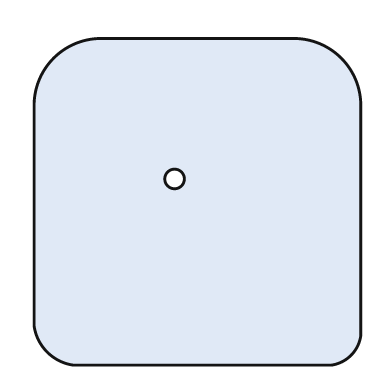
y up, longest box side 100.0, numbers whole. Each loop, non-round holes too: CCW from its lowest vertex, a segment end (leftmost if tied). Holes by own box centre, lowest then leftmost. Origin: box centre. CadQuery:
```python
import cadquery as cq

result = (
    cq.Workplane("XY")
    .moveTo(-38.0, -50.0)
    .lineTo(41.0, -50.0)
    .threePointArc((47.0, -47.0), (50.0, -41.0))
    .lineTo(50.0, 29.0)
    .threePointArc((44.0, 44.0), (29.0, 50.0))
    .lineTo(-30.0, 50.0)
    .threePointArc((-44.0, 44.0), (-50.0, 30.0))
    .lineTo(-50.0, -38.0)
    .threePointArc((-46.0, -46.0), (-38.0, -50.0))
    .close()
    .moveTo(-7.0, 7.0)
    .circle(3.0)
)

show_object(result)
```